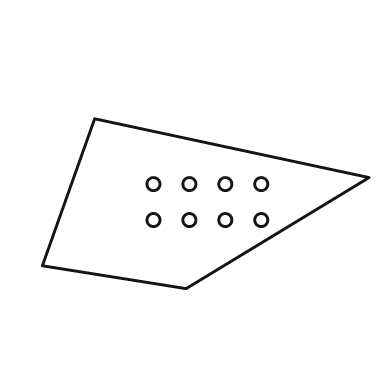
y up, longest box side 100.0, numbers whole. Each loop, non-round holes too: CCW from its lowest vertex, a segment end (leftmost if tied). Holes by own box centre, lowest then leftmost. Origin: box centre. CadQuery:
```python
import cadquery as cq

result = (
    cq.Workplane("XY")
    .moveTo(-6.0, -26.0)
    .lineTo(50.0, 8.0)
    .lineTo(-34.0, 26.0)
    .lineTo(-50.0, -19.0)
    .close()
    .moveTo(-16.0, -5.0)
    .circle(2.0)
    .moveTo(-5.0, -5.0)
    .circle(2.0)
    .moveTo(6.0, -5.0)
    .circle(2.0)
    .moveTo(17.0, -5.0)
    .circle(2.0)
    .moveTo(-16.0, 6.0)
    .circle(2.0)
    .moveTo(-5.0, 6.0)
    .circle(2.0)
    .moveTo(6.0, 6.0)
    .circle(2.0)
    .moveTo(17.0, 6.0)
    .circle(2.0)
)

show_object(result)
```